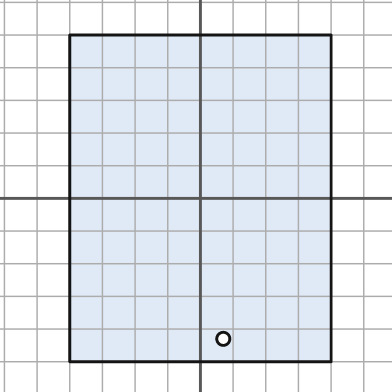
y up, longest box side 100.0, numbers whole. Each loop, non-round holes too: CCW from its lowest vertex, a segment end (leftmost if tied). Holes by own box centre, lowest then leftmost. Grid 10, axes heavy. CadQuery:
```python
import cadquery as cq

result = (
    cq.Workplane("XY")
    .moveTo(-40.0, -50.0)
    .lineTo(40.0, -50.0)
    .lineTo(40.0, 50.0)
    .lineTo(-40.0, 50.0)
    .close()
    .moveTo(7.0, -43.0)
    .circle(2.0)
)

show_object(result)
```